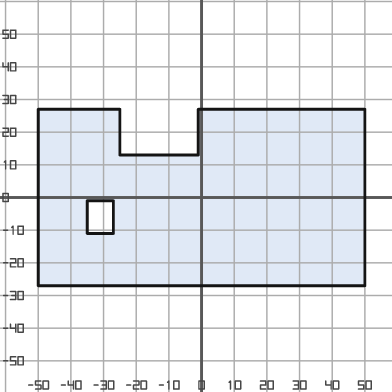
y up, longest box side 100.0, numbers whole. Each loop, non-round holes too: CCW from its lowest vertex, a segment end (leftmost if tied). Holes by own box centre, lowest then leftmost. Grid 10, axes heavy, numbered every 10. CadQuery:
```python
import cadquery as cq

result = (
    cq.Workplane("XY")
    .moveTo(-50.0, -27.0)
    .lineTo(50.0, -27.0)
    .lineTo(50.0, 27.0)
    .lineTo(-1.0, 27.0)
    .lineTo(-1.0, 13.0)
    .lineTo(-25.0, 13.0)
    .lineTo(-25.0, 27.0)
    .lineTo(-50.0, 27.0)
    .close()
    .moveTo(-35.0, -11.0)
    .lineTo(-27.0, -11.0)
    .lineTo(-27.0, -1.0)
    .lineTo(-35.0, -1.0)
    .close()
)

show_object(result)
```